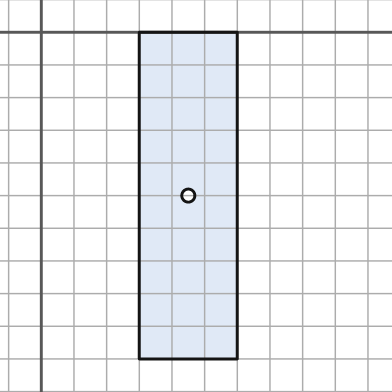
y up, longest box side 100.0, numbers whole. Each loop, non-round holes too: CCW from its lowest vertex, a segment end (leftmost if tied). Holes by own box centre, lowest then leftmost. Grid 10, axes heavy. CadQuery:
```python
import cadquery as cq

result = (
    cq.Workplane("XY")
    .moveTo(30.0, -100.0)
    .lineTo(60.0, -100.0)
    .lineTo(60.0, 0.0)
    .lineTo(30.0, 0.0)
    .close()
    .moveTo(45.0, -50.0)
    .circle(2.0)
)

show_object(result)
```